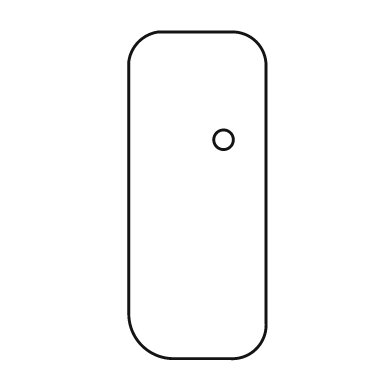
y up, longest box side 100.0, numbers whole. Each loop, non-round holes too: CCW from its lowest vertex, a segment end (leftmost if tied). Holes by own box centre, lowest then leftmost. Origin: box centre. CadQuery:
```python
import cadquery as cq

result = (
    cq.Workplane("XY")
    .moveTo(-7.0, -50.0)
    .lineTo(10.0, -50.0)
    .threePointArc((18.0, -47.0), (21.0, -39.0))
    .lineTo(21.0, 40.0)
    .threePointArc((18.0, 47.0), (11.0, 50.0))
    .lineTo(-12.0, 50.0)
    .threePointArc((-18.0, 47.0), (-21.0, 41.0))
    .lineTo(-21.0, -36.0)
    .threePointArc((-17.0, -46.0), (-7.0, -50.0))
    .close()
    .moveTo(8.0, 17.0)
    .circle(3.0)
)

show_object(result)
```